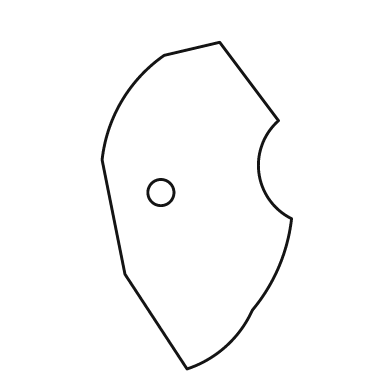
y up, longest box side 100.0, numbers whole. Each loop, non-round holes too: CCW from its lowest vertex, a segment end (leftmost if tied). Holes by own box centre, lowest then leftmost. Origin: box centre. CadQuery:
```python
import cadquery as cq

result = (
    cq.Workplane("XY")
    .moveTo(-3.0, -50.0)
    .threePointArc((9.0, -43.0), (17.0, -32.0))
    .threePointArc((25.0, -19.0), (29.0, -4.0))
    .threePointArc((19.0, 10.0), (25.0, 26.0))
    .lineTo(7.0, 50.0)
    .lineTo(-10.0, 46.0)
    .threePointArc((-23.0, 32.0), (-29.0, 14.0))
    .lineTo(-22.0, -21.0)
    .close()
    .moveTo(-11.0, 4.0)
    .circle(4.0)
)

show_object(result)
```